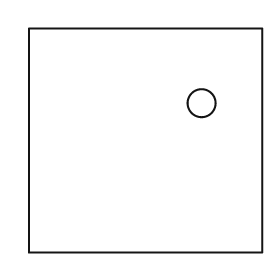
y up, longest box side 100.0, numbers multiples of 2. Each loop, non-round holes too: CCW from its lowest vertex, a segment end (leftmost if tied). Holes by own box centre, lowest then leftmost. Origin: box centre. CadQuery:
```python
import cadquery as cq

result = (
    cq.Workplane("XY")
    .moveTo(-50.0, -48.0)
    .lineTo(50.0, -48.0)
    .lineTo(50.0, 48.0)
    .lineTo(-50.0, 48.0)
    .close()
    .moveTo(24.0, 16.0)
    .circle(6.0)
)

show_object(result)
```